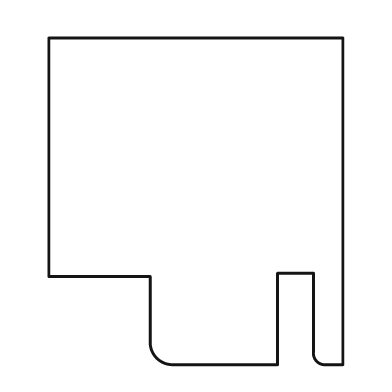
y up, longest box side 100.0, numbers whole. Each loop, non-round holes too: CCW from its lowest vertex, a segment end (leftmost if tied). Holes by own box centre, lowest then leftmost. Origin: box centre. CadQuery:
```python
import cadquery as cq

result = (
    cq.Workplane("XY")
    .moveTo(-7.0, -50.0)
    .lineTo(25.0, -50.0)
    .lineTo(25.0, -22.0)
    .lineTo(36.0, -22.0)
    .lineTo(36.0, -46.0)
    .threePointArc((37.0, -49.0), (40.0, -50.0))
    .lineTo(45.0, -50.0)
    .lineTo(45.0, 50.0)
    .lineTo(-45.0, 50.0)
    .lineTo(-45.0, -23.0)
    .lineTo(-14.0, -23.0)
    .lineTo(-14.0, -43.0)
    .threePointArc((-12.0, -48.0), (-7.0, -50.0))
    .close()
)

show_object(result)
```